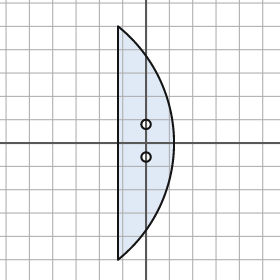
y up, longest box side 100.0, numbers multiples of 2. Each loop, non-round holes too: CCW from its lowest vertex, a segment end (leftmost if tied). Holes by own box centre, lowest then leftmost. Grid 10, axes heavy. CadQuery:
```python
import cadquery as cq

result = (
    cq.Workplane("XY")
    .moveTo(-12.0, -50.0)
    .threePointArc((12.0, 0.0), (-12.0, 50.0))
    .close()
    .moveTo(0.0, -6.0)
    .circle(2.0)
    .moveTo(0.0, 8.0)
    .circle(2.0)
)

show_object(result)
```